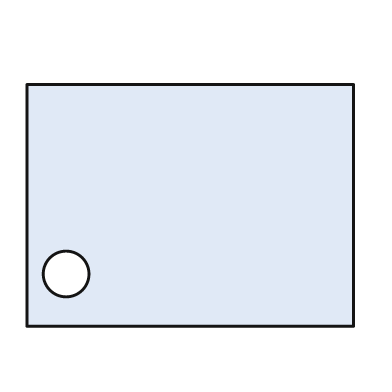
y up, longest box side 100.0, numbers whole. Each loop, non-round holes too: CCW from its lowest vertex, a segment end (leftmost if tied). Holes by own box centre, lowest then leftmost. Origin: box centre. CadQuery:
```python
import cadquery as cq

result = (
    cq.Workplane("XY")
    .moveTo(-50.0, -37.0)
    .lineTo(50.0, -37.0)
    .lineTo(50.0, 37.0)
    .lineTo(-50.0, 37.0)
    .close()
    .moveTo(-38.0, -21.0)
    .circle(7.0)
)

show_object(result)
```